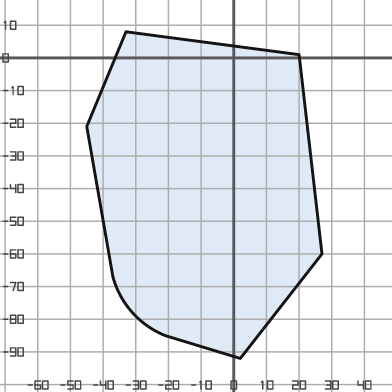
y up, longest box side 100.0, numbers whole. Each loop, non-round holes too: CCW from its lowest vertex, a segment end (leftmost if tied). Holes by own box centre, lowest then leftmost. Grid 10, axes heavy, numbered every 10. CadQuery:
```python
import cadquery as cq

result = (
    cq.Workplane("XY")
    .moveTo(2.0, -92.0)
    .lineTo(27.0, -60.0)
    .lineTo(20.0, 1.0)
    .lineTo(-33.0, 8.0)
    .lineTo(-45.0, -21.0)
    .lineTo(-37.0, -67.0)
    .threePointArc((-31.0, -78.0), (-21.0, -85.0))
    .close()
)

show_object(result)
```